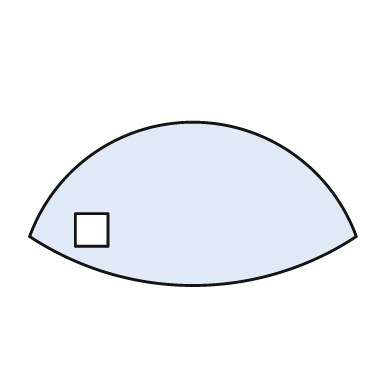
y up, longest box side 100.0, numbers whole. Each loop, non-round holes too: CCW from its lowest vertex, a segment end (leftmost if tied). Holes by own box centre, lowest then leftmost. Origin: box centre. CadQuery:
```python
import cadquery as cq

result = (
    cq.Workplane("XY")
    .moveTo(-50.0, -10.0)
    .threePointArc((0.0, -25.0), (50.0, -10.0))
    .threePointArc((0.0, 25.0), (-50.0, -10.0))
    .close()
    .moveTo(-36.0, -13.0)
    .lineTo(-26.0, -13.0)
    .lineTo(-26.0, -3.0)
    .lineTo(-36.0, -3.0)
    .close()
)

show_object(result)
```